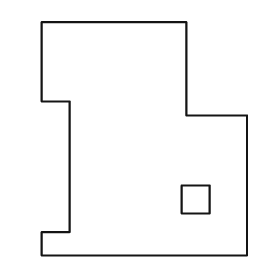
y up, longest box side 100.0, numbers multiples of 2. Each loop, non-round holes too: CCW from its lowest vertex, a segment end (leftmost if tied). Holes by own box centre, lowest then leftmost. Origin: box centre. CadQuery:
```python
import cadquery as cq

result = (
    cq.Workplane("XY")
    .moveTo(-44.0, -50.0)
    .lineTo(44.0, -50.0)
    .lineTo(44.0, 10.0)
    .lineTo(18.0, 10.0)
    .lineTo(18.0, 50.0)
    .lineTo(-44.0, 50.0)
    .lineTo(-44.0, 16.0)
    .lineTo(-32.0, 16.0)
    .lineTo(-32.0, -40.0)
    .lineTo(-44.0, -40.0)
    .close()
    .moveTo(16.0, -32.0)
    .lineTo(28.0, -32.0)
    .lineTo(28.0, -20.0)
    .lineTo(16.0, -20.0)
    .close()
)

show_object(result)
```